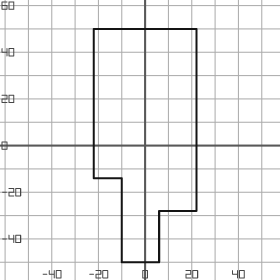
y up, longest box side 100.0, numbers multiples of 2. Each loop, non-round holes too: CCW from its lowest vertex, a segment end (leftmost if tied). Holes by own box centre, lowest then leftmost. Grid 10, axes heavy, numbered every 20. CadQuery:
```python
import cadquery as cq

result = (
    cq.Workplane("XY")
    .moveTo(-10.0, -50.0)
    .lineTo(6.0, -50.0)
    .lineTo(6.0, -28.0)
    .lineTo(22.0, -28.0)
    .lineTo(22.0, 50.0)
    .lineTo(-22.0, 50.0)
    .lineTo(-22.0, -14.0)
    .lineTo(-10.0, -14.0)
    .close()
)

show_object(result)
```